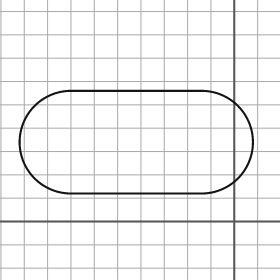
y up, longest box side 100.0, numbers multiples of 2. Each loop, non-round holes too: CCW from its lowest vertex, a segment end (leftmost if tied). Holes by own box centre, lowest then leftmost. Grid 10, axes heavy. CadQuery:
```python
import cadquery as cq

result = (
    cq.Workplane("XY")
    .moveTo(-70.0, 12.0)
    .lineTo(-14.0, 12.0)
    .threePointArc((8.0, 34.0), (-14.0, 56.0))
    .lineTo(-70.0, 56.0)
    .threePointArc((-92.0, 34.0), (-70.0, 12.0))
    .close()
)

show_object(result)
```